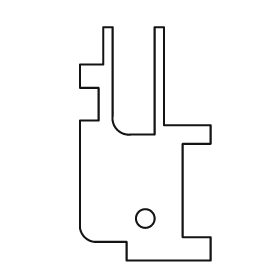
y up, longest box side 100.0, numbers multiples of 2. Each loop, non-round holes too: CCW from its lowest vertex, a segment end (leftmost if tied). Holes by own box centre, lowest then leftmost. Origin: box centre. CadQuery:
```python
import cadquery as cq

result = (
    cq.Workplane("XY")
    .moveTo(-8.0, -50.0)
    .lineTo(28.0, -50.0)
    .lineTo(28.0, -40.0)
    .lineTo(16.0, -40.0)
    .lineTo(16.0, 0.0)
    .lineTo(28.0, 0.0)
    .lineTo(28.0, 8.0)
    .lineTo(8.0, 8.0)
    .lineTo(8.0, 50.0)
    .lineTo(4.0, 50.0)
    .lineTo(4.0, 4.0)
    .lineTo(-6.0, 4.0)
    .threePointArc((-12.0, 6.0), (-14.0, 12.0))
    .lineTo(-14.0, 50.0)
    .lineTo(-18.0, 50.0)
    .lineTo(-18.0, 34.0)
    .lineTo(-28.0, 34.0)
    .lineTo(-28.0, 24.0)
    .lineTo(-20.0, 24.0)
    .lineTo(-20.0, 10.0)
    .lineTo(-28.0, 10.0)
    .lineTo(-28.0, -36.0)
    .threePointArc((-26.0, -40.0), (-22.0, -42.0))
    .lineTo(-8.0, -42.0)
    .close()
    .moveTo(0.0, -32.0)
    .circle(4.0)
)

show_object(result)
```